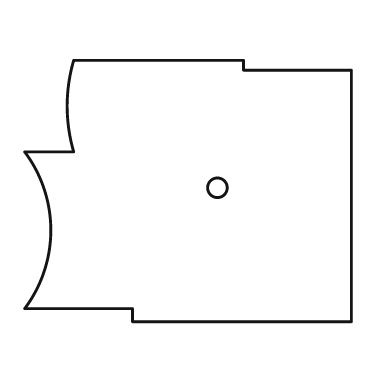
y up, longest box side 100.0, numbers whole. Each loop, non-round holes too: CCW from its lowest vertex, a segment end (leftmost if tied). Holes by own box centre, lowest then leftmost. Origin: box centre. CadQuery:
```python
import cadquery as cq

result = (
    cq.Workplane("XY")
    .moveTo(-17.0, -40.0)
    .lineTo(50.0, -40.0)
    .lineTo(50.0, 37.0)
    .lineTo(17.0, 37.0)
    .lineTo(17.0, 40.0)
    .lineTo(-35.0, 40.0)
    .threePointArc((-37.0, 26.0), (-35.0, 12.0))
    .lineTo(-50.0, 12.0)
    .threePointArc((-42.0, -12.0), (-50.0, -36.0))
    .lineTo(-17.0, -36.0)
    .close()
    .moveTo(9.0, 1.0)
    .circle(3.0)
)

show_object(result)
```